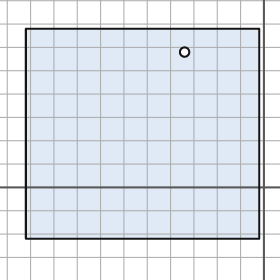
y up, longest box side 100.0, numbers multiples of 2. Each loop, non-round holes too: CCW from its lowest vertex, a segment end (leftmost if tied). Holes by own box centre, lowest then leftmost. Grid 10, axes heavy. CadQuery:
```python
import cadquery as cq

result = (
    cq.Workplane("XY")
    .moveTo(-102.0, -22.0)
    .lineTo(-2.0, -22.0)
    .lineTo(-2.0, 68.0)
    .lineTo(-102.0, 68.0)
    .close()
    .moveTo(-34.0, 58.0)
    .circle(2.0)
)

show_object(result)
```